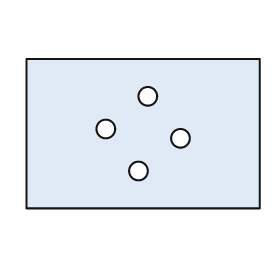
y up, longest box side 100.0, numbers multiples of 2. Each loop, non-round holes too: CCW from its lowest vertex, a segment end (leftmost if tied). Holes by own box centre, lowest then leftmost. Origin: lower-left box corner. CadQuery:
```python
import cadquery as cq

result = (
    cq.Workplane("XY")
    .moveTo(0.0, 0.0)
    .lineTo(100.0, 0.0)
    .lineTo(100.0, 64.0)
    .lineTo(0.0, 64.0)
    .close()
    .moveTo(48.0, 16.0)
    .circle(4.0)
    .moveTo(66.0, 30.0)
    .circle(4.0)
    .moveTo(34.0, 34.0)
    .circle(4.0)
    .moveTo(52.0, 48.0)
    .circle(4.0)
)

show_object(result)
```